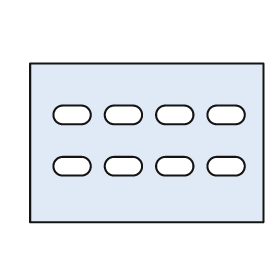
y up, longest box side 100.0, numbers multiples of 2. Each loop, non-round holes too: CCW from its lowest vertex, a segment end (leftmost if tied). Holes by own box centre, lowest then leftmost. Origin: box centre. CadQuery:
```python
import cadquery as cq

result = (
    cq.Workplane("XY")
    .moveTo(-50.0, -34.0)
    .lineTo(50.0, -34.0)
    .lineTo(50.0, 34.0)
    .lineTo(-50.0, 34.0)
    .close()
    .moveTo(-36.0, -14.0)
    .lineTo(-28.0, -14.0)
    .threePointArc((-24.0, -10.0), (-28.0, -6.0))
    .lineTo(-36.0, -6.0)
    .threePointArc((-40.0, -10.0), (-36.0, -14.0))
    .close()
    .moveTo(-14.0, -14.0)
    .lineTo(-6.0, -14.0)
    .threePointArc((-2.0, -10.0), (-6.0, -6.0))
    .lineTo(-14.0, -6.0)
    .threePointArc((-18.0, -10.0), (-14.0, -14.0))
    .close()
    .moveTo(8.0, -14.0)
    .lineTo(16.0, -14.0)
    .threePointArc((20.0, -10.0), (16.0, -6.0))
    .lineTo(8.0, -6.0)
    .threePointArc((4.0, -10.0), (8.0, -14.0))
    .close()
    .moveTo(30.0, -14.0)
    .lineTo(38.0, -14.0)
    .threePointArc((42.0, -10.0), (38.0, -6.0))
    .lineTo(30.0, -6.0)
    .threePointArc((26.0, -10.0), (30.0, -14.0))
    .close()
    .moveTo(-36.0, 8.0)
    .lineTo(-28.0, 8.0)
    .threePointArc((-24.0, 12.0), (-28.0, 16.0))
    .lineTo(-36.0, 16.0)
    .threePointArc((-40.0, 12.0), (-36.0, 8.0))
    .close()
    .moveTo(-14.0, 8.0)
    .lineTo(-6.0, 8.0)
    .threePointArc((-2.0, 12.0), (-6.0, 16.0))
    .lineTo(-14.0, 16.0)
    .threePointArc((-18.0, 12.0), (-14.0, 8.0))
    .close()
    .moveTo(8.0, 8.0)
    .lineTo(16.0, 8.0)
    .threePointArc((20.0, 12.0), (16.0, 16.0))
    .lineTo(8.0, 16.0)
    .threePointArc((4.0, 12.0), (8.0, 8.0))
    .close()
    .moveTo(30.0, 8.0)
    .lineTo(38.0, 8.0)
    .threePointArc((42.0, 12.0), (38.0, 16.0))
    .lineTo(30.0, 16.0)
    .threePointArc((26.0, 12.0), (30.0, 8.0))
    .close()
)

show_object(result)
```